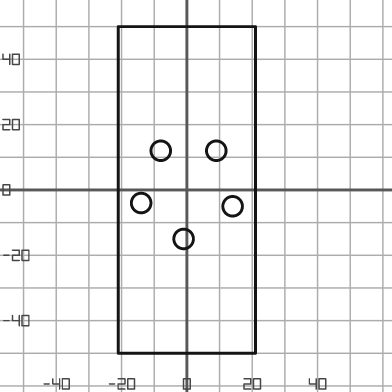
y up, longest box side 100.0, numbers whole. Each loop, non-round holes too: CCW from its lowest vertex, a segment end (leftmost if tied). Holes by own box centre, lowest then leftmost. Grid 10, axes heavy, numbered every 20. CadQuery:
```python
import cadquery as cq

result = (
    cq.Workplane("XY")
    .moveTo(-21.0, -50.0)
    .lineTo(21.0, -50.0)
    .lineTo(21.0, 50.0)
    .lineTo(-21.0, 50.0)
    .close()
    .moveTo(-1.0, -15.0)
    .circle(3.0)
    .moveTo(14.0, -5.0)
    .circle(3.0)
    .moveTo(-14.0, -4.0)
    .circle(3.0)
    .moveTo(-8.0, 12.0)
    .circle(3.0)
    .moveTo(9.0, 12.0)
    .circle(3.0)
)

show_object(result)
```